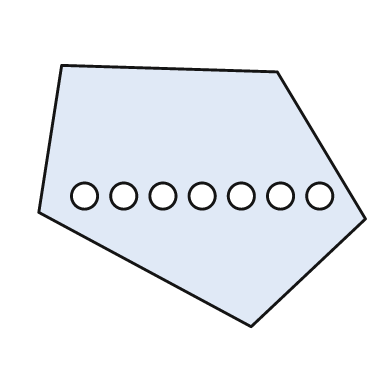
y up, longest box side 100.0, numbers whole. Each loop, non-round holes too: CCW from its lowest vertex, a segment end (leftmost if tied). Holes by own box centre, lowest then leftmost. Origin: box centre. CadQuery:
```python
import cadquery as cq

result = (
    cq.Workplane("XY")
    .moveTo(15.0, -40.0)
    .lineTo(50.0, -7.0)
    .lineTo(23.0, 38.0)
    .lineTo(-43.0, 40.0)
    .lineTo(-50.0, -5.0)
    .close()
    .moveTo(-36.0, 0.0)
    .circle(4.0)
    .moveTo(-24.0, 0.0)
    .circle(4.0)
    .moveTo(-12.0, 0.0)
    .circle(4.0)
    .moveTo(0.0, 0.0)
    .circle(4.0)
    .moveTo(12.0, 0.0)
    .circle(4.0)
    .moveTo(24.0, 0.0)
    .circle(4.0)
    .moveTo(36.0, 0.0)
    .circle(4.0)
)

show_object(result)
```